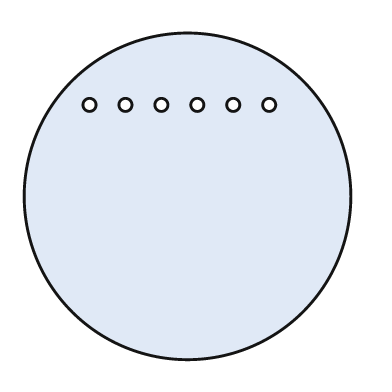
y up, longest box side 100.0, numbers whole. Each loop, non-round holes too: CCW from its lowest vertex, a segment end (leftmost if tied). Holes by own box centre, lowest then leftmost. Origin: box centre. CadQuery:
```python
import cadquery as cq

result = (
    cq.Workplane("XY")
    .moveTo(0.0, 0.0)
    .circle(50.0)
    .moveTo(-30.0, 28.0)
    .circle(2.0)
    .moveTo(-19.0, 28.0)
    .circle(2.0)
    .moveTo(-8.0, 28.0)
    .circle(2.0)
    .moveTo(3.0, 28.0)
    .circle(2.0)
    .moveTo(14.0, 28.0)
    .circle(2.0)
    .moveTo(25.0, 28.0)
    .circle(2.0)
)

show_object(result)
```